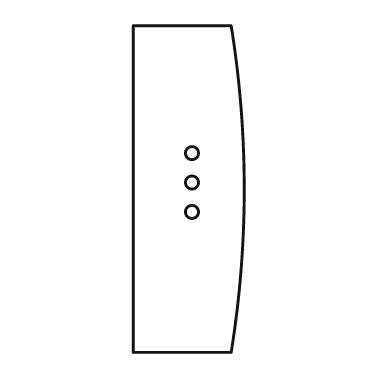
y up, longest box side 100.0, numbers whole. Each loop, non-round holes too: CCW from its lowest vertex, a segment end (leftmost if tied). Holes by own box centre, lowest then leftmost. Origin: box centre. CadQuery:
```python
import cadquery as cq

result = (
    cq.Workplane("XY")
    .moveTo(-17.0, -50.0)
    .lineTo(13.0, -50.0)
    .threePointArc((17.0, 0.0), (13.0, 50.0))
    .lineTo(-17.0, 50.0)
    .close()
    .moveTo(1.0, -7.0)
    .circle(2.0)
    .moveTo(1.0, 2.0)
    .circle(2.0)
    .moveTo(1.0, 11.0)
    .circle(2.0)
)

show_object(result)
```